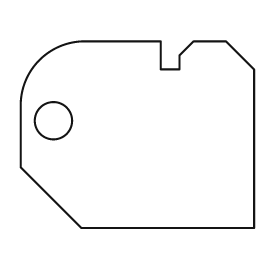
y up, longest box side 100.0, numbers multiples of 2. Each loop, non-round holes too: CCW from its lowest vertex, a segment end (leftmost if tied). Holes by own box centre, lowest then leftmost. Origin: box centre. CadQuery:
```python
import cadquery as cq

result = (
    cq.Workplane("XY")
    .moveTo(-24.0, -40.0)
    .lineTo(50.0, -40.0)
    .lineTo(50.0, 28.0)
    .lineTo(38.0, 40.0)
    .lineTo(24.0, 40.0)
    .lineTo(18.0, 34.0)
    .lineTo(18.0, 28.0)
    .lineTo(10.0, 28.0)
    .lineTo(10.0, 40.0)
    .lineTo(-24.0, 40.0)
    .threePointArc((-42.0, 32.0), (-50.0, 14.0))
    .lineTo(-50.0, -14.0)
    .close()
    .moveTo(-36.0, 6.0)
    .circle(8.0)
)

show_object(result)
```